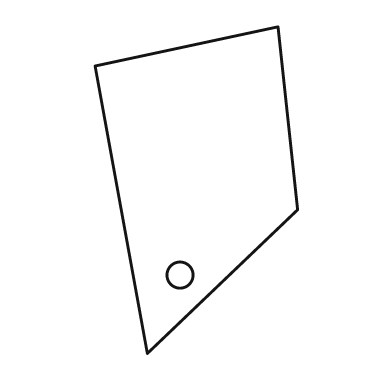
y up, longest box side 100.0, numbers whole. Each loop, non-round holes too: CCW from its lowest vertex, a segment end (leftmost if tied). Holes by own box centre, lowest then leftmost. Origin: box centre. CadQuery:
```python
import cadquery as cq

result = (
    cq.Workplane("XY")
    .moveTo(-15.0, -50.0)
    .lineTo(31.0, -6.0)
    .lineTo(25.0, 50.0)
    .lineTo(-31.0, 38.0)
    .close()
    .moveTo(-5.0, -26.0)
    .circle(4.0)
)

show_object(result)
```